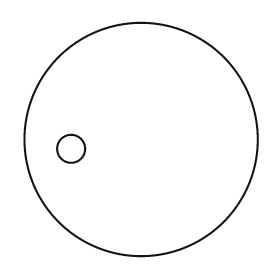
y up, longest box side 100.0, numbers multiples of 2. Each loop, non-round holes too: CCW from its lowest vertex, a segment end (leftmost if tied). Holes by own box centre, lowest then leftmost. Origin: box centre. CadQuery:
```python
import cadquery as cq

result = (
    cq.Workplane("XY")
    .moveTo(0.0, 0.0)
    .circle(50.0)
    .moveTo(-30.0, -4.0)
    .circle(6.0)
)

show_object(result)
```